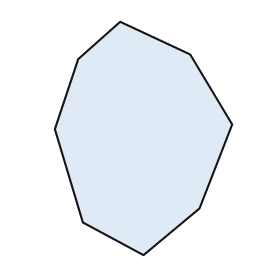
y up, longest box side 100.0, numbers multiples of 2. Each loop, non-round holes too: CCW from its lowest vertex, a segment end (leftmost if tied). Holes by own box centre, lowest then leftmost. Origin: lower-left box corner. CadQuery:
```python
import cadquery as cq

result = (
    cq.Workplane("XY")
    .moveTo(38.0, 0.0)
    .lineTo(62.0, 20.0)
    .lineTo(76.0, 56.0)
    .lineTo(58.0, 86.0)
    .lineTo(28.0, 100.0)
    .lineTo(10.0, 84.0)
    .lineTo(0.0, 54.0)
    .lineTo(12.0, 14.0)
    .close()
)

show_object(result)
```